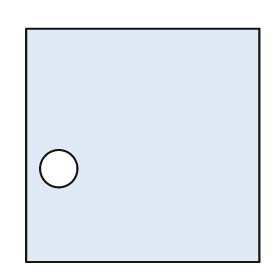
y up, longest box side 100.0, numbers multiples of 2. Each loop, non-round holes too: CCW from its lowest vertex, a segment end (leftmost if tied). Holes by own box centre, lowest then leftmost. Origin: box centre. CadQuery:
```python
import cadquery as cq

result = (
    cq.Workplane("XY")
    .moveTo(-50.0, -50.0)
    .lineTo(50.0, -50.0)
    .lineTo(50.0, 50.0)
    .lineTo(-50.0, 50.0)
    .close()
    .moveTo(-36.0, -10.0)
    .circle(8.0)
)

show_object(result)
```